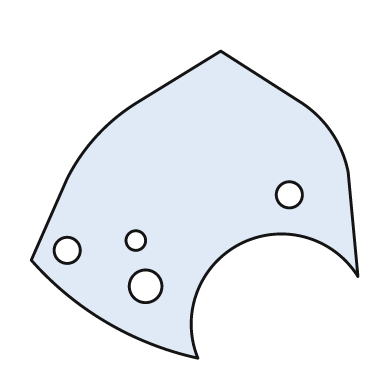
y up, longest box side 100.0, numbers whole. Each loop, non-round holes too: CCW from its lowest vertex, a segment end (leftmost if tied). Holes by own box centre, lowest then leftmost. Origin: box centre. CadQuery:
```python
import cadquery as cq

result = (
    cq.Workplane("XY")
    .moveTo(1.0, -47.0)
    .threePointArc((14.0, -12.0), (50.0, -22.0))
    .lineTo(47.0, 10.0)
    .threePointArc((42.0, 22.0), (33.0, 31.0))
    .lineTo(8.0, 47.0)
    .lineTo(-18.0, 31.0)
    .threePointArc((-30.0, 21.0), (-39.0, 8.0))
    .lineTo(-50.0, -17.0)
    .threePointArc((-27.0, -36.0), (1.0, -47.0))
    .close()
    .moveTo(-15.0, -25.0)
    .circle(5.0)
    .moveTo(-39.0, -14.0)
    .circle(4.0)
    .moveTo(-18.0, -11.0)
    .circle(3.0)
    .moveTo(29.0, 3.0)
    .circle(4.0)
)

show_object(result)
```